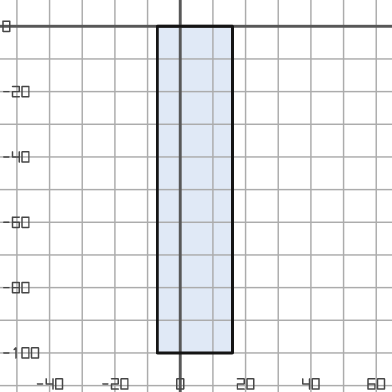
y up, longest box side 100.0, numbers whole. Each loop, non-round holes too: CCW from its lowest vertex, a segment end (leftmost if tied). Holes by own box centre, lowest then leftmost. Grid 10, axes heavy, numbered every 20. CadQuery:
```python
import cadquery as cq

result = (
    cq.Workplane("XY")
    .moveTo(-7.0, -100.0)
    .lineTo(16.0, -100.0)
    .lineTo(16.0, 0.0)
    .lineTo(-7.0, 0.0)
    .close()
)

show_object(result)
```